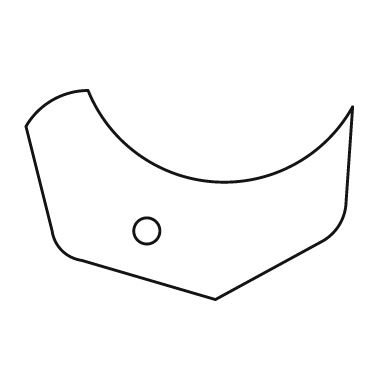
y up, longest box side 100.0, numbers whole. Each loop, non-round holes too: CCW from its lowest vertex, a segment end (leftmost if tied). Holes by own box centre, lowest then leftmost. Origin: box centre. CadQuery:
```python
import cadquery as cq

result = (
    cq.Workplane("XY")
    .moveTo(8.0, -32.0)
    .lineTo(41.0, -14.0)
    .threePointArc((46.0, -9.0), (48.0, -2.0))
    .lineTo(50.0, 27.0)
    .threePointArc((8.0, 4.0), (-31.0, 32.0))
    .threePointArc((-42.0, 29.0), (-50.0, 21.0))
    .lineTo(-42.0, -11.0)
    .threePointArc((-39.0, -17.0), (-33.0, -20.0))
    .close()
    .moveTo(-13.0, -11.0)
    .circle(4.0)
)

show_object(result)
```